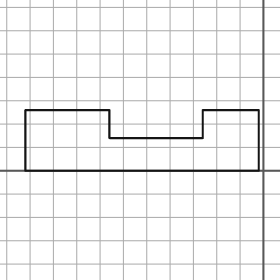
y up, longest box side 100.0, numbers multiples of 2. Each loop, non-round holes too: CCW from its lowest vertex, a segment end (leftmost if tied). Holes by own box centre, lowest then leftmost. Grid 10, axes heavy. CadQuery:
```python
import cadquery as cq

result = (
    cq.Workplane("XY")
    .moveTo(-102.0, 0.0)
    .lineTo(-2.0, 0.0)
    .lineTo(-2.0, 26.0)
    .lineTo(-26.0, 26.0)
    .lineTo(-26.0, 14.0)
    .lineTo(-66.0, 14.0)
    .lineTo(-66.0, 26.0)
    .lineTo(-102.0, 26.0)
    .close()
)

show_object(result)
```